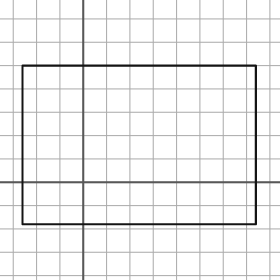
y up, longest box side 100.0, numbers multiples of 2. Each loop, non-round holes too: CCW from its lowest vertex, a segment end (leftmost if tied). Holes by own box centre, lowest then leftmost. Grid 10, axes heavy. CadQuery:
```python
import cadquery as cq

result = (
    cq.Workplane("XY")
    .moveTo(-26.0, -18.0)
    .lineTo(74.0, -18.0)
    .lineTo(74.0, 50.0)
    .lineTo(-26.0, 50.0)
    .close()
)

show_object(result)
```